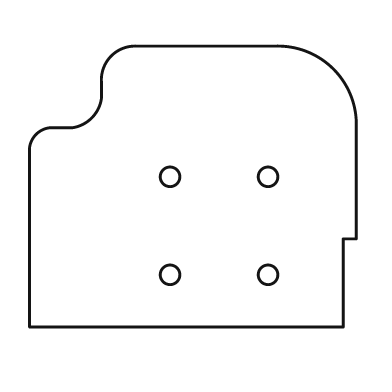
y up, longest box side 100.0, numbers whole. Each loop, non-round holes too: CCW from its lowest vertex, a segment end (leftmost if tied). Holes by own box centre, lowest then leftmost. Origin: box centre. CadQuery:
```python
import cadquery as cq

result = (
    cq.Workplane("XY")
    .moveTo(-50.0, -43.0)
    .lineTo(46.0, -43.0)
    .lineTo(46.0, -16.0)
    .lineTo(50.0, -16.0)
    .lineTo(50.0, 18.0)
    .threePointArc((43.0, 36.0), (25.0, 43.0))
    .lineTo(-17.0, 43.0)
    .threePointArc((-25.0, 40.0), (-28.0, 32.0))
    .lineTo(-28.0, 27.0)
    .threePointArc((-31.0, 21.0), (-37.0, 18.0))
    .lineTo(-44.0, 18.0)
    .threePointArc((-48.0, 16.0), (-50.0, 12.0))
    .close()
    .moveTo(-7.0, -27.0)
    .circle(3.0)
    .moveTo(23.0, -27.0)
    .circle(3.0)
    .moveTo(-7.0, 3.0)
    .circle(3.0)
    .moveTo(23.0, 3.0)
    .circle(3.0)
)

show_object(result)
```